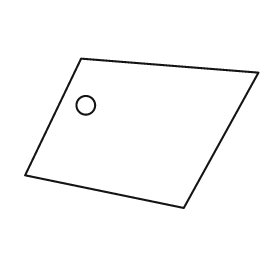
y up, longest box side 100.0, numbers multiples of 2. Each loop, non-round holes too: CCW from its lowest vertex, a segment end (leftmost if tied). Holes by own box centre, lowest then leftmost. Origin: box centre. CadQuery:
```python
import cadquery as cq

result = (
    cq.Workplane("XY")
    .moveTo(18.0, -32.0)
    .lineTo(50.0, 26.0)
    .lineTo(-26.0, 32.0)
    .lineTo(-50.0, -18.0)
    .close()
    .moveTo(-24.0, 12.0)
    .circle(4.0)
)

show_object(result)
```